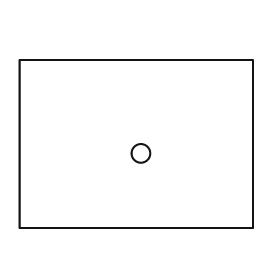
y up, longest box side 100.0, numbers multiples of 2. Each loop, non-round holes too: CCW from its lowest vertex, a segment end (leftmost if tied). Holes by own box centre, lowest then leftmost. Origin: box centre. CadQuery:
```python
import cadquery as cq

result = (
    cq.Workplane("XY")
    .moveTo(-50.0, -36.0)
    .lineTo(50.0, -36.0)
    .lineTo(50.0, 36.0)
    .lineTo(-50.0, 36.0)
    .close()
    .moveTo(2.0, -4.0)
    .circle(4.0)
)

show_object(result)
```